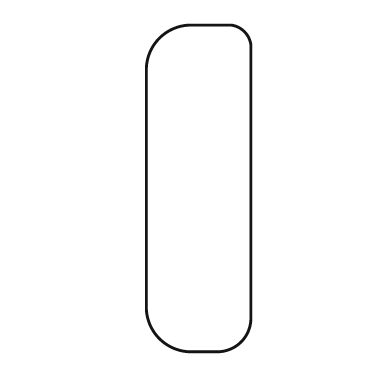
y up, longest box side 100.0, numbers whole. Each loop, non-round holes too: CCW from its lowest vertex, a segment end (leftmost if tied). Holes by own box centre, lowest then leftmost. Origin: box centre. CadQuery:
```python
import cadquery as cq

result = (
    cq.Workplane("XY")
    .moveTo(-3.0, -50.0)
    .lineTo(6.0, -50.0)
    .threePointArc((13.0, -47.0), (16.0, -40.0))
    .lineTo(16.0, 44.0)
    .threePointArc((14.0, 48.0), (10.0, 50.0))
    .lineTo(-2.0, 50.0)
    .threePointArc((-12.0, 46.0), (-16.0, 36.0))
    .lineTo(-16.0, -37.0)
    .threePointArc((-12.0, -46.0), (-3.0, -50.0))
    .close()
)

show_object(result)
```